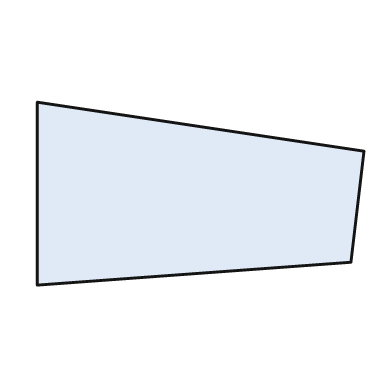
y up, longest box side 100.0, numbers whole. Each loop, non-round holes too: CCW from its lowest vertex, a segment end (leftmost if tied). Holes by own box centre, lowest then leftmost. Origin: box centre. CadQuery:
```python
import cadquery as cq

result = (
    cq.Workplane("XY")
    .moveTo(-50.0, -28.0)
    .lineTo(46.0, -21.0)
    .lineTo(50.0, 13.0)
    .lineTo(-50.0, 28.0)
    .close()
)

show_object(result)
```